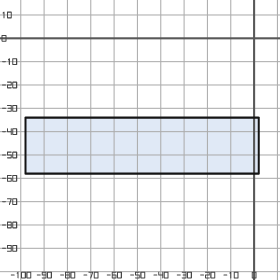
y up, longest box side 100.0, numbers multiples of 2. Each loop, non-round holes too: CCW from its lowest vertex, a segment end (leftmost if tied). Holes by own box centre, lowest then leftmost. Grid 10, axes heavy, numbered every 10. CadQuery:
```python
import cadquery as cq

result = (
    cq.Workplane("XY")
    .moveTo(-98.0, -58.0)
    .lineTo(2.0, -58.0)
    .lineTo(2.0, -34.0)
    .lineTo(-98.0, -34.0)
    .close()
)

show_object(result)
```